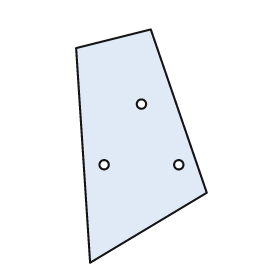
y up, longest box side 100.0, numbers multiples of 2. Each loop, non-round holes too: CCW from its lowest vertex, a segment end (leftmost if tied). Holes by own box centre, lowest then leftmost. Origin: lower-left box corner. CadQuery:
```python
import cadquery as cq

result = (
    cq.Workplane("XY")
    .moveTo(6.0, 0.0)
    .lineTo(56.0, 30.0)
    .lineTo(32.0, 100.0)
    .lineTo(0.0, 92.0)
    .close()
    .moveTo(12.0, 42.0)
    .circle(2.0)
    .moveTo(44.0, 42.0)
    .circle(2.0)
    .moveTo(28.0, 68.0)
    .circle(2.0)
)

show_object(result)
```